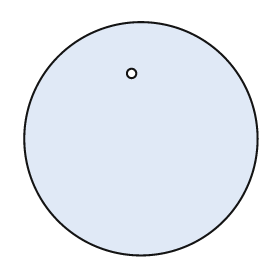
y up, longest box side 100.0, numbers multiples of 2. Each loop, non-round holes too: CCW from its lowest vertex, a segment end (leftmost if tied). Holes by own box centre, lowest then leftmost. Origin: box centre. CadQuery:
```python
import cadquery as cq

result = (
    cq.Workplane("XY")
    .moveTo(0.0, 0.0)
    .circle(50.0)
    .moveTo(-4.0, 28.0)
    .circle(2.0)
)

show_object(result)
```